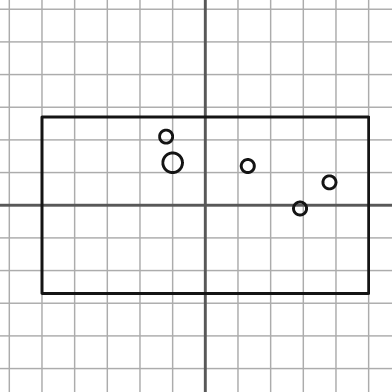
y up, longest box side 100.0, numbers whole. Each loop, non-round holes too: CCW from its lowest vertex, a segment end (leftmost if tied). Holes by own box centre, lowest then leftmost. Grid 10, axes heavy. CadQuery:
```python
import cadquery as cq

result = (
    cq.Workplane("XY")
    .moveTo(-50.0, -27.0)
    .lineTo(50.0, -27.0)
    .lineTo(50.0, 27.0)
    .lineTo(-50.0, 27.0)
    .close()
    .moveTo(29.0, -1.0)
    .circle(2.0)
    .moveTo(38.0, 7.0)
    .circle(2.0)
    .moveTo(13.0, 12.0)
    .circle(2.0)
    .moveTo(-10.0, 13.0)
    .circle(3.0)
    .moveTo(-12.0, 21.0)
    .circle(2.0)
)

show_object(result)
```